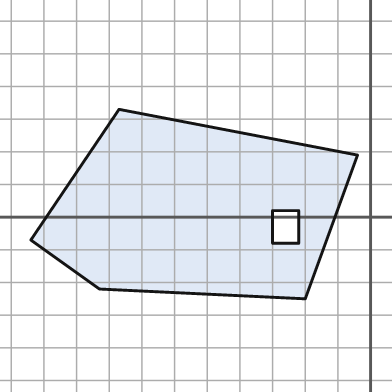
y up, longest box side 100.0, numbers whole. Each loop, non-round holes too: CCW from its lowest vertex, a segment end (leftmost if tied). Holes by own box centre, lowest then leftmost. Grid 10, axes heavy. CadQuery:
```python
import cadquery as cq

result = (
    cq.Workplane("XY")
    .moveTo(-20.0, -25.0)
    .lineTo(-4.0, 19.0)
    .lineTo(-77.0, 33.0)
    .lineTo(-104.0, -7.0)
    .lineTo(-83.0, -22.0)
    .close()
    .moveTo(-30.0, -8.0)
    .lineTo(-22.0, -8.0)
    .lineTo(-22.0, 2.0)
    .lineTo(-30.0, 2.0)
    .close()
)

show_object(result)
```